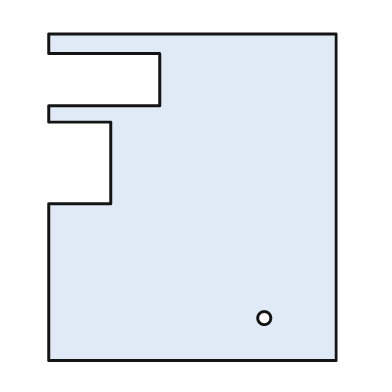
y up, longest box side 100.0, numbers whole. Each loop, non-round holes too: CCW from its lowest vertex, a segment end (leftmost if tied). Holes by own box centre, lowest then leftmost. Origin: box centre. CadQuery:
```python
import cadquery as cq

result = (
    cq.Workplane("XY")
    .moveTo(-44.0, -50.0)
    .lineTo(44.0, -50.0)
    .lineTo(44.0, 50.0)
    .lineTo(-44.0, 50.0)
    .lineTo(-44.0, 44.0)
    .lineTo(-10.0, 44.0)
    .lineTo(-10.0, 28.0)
    .lineTo(-44.0, 28.0)
    .lineTo(-44.0, 23.0)
    .lineTo(-25.0, 23.0)
    .lineTo(-25.0, -2.0)
    .lineTo(-44.0, -2.0)
    .close()
    .moveTo(22.0, -37.0)
    .circle(2.0)
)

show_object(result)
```